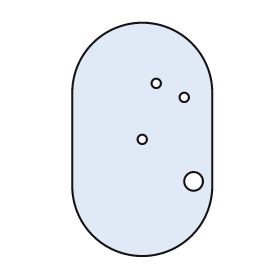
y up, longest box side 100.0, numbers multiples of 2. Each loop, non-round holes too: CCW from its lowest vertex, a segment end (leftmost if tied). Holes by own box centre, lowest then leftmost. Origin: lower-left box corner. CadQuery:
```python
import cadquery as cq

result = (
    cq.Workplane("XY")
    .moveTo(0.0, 30.0)
    .threePointArc((30.0, 0.0), (60.0, 30.0))
    .lineTo(60.0, 70.0)
    .threePointArc((30.0, 100.0), (0.0, 70.0))
    .close()
    .moveTo(52.0, 32.0)
    .circle(4.0)
    .moveTo(30.0, 50.0)
    .circle(2.0)
    .moveTo(48.0, 68.0)
    .circle(2.0)
    .moveTo(36.0, 74.0)
    .circle(2.0)
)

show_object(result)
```